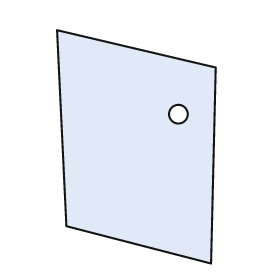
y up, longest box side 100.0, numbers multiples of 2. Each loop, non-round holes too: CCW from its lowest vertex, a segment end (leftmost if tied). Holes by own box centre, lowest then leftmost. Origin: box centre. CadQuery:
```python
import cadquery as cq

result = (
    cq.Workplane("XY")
    .moveTo(32.0, -50.0)
    .lineTo(34.0, 34.0)
    .lineTo(-34.0, 50.0)
    .lineTo(-30.0, -34.0)
    .close()
    .moveTo(18.0, 14.0)
    .circle(4.0)
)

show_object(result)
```